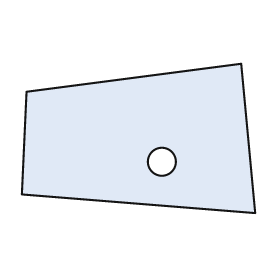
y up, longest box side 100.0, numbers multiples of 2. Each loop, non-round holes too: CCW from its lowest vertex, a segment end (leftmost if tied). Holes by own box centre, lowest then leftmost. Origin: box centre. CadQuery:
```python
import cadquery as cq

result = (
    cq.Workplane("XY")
    .moveTo(50.0, -32.0)
    .lineTo(44.0, 32.0)
    .lineTo(-48.0, 20.0)
    .lineTo(-50.0, -24.0)
    .close()
    .moveTo(10.0, -10.0)
    .circle(6.0)
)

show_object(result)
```